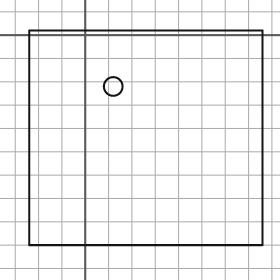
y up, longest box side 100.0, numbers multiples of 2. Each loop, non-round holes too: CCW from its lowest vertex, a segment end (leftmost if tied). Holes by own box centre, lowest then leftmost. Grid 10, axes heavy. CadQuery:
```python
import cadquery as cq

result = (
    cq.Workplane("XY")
    .moveTo(-24.0, -90.0)
    .lineTo(76.0, -90.0)
    .lineTo(76.0, 2.0)
    .lineTo(-24.0, 2.0)
    .close()
    .moveTo(12.0, -22.0)
    .circle(4.0)
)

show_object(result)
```